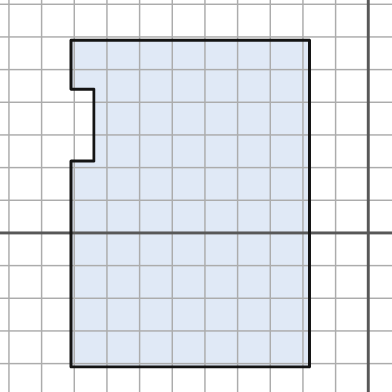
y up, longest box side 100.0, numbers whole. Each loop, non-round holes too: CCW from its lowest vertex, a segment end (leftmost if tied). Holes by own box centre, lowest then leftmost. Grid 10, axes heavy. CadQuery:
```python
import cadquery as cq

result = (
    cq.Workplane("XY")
    .moveTo(-91.0, -41.0)
    .lineTo(-18.0, -41.0)
    .lineTo(-18.0, 59.0)
    .lineTo(-91.0, 59.0)
    .lineTo(-91.0, 44.0)
    .lineTo(-84.0, 44.0)
    .lineTo(-84.0, 22.0)
    .lineTo(-91.0, 22.0)
    .close()
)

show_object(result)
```